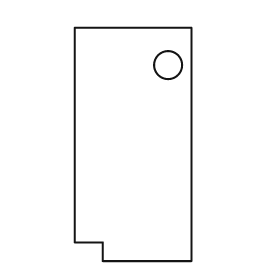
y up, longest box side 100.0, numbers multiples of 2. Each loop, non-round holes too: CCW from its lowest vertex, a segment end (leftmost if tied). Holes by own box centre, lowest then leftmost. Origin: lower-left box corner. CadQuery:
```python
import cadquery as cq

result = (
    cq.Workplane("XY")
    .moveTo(12.0, 0.0)
    .lineTo(50.0, 0.0)
    .lineTo(50.0, 100.0)
    .lineTo(0.0, 100.0)
    .lineTo(0.0, 8.0)
    .lineTo(12.0, 8.0)
    .close()
    .moveTo(40.0, 84.0)
    .circle(6.0)
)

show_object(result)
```